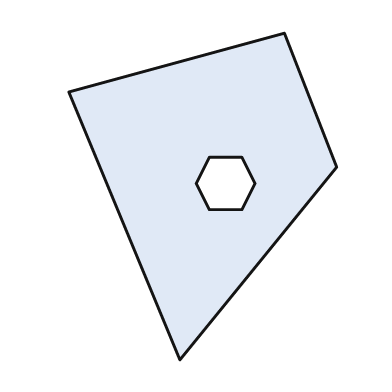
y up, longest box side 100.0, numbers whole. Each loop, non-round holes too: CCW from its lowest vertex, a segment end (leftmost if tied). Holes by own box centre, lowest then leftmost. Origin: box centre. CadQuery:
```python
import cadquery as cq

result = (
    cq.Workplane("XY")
    .moveTo(-7.0, -50.0)
    .lineTo(41.0, 9.0)
    .lineTo(25.0, 50.0)
    .lineTo(-41.0, 32.0)
    .close()
    .moveTo(2.0, -4.0)
    .lineTo(12.0, -4.0)
    .lineTo(16.0, 4.0)
    .lineTo(12.0, 12.0)
    .lineTo(2.0, 12.0)
    .lineTo(-2.0, 4.0)
    .close()
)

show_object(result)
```